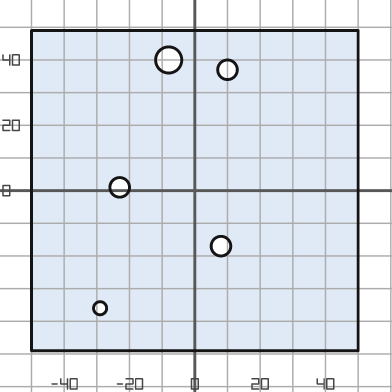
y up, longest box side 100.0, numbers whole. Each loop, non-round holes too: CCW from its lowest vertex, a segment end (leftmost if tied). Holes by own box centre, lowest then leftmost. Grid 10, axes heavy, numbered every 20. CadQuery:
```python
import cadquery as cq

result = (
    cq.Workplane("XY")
    .moveTo(-50.0, -49.0)
    .lineTo(50.0, -49.0)
    .lineTo(50.0, 49.0)
    .lineTo(-50.0, 49.0)
    .close()
    .moveTo(-29.0, -36.0)
    .circle(2.0)
    .moveTo(8.0, -17.0)
    .circle(3.0)
    .moveTo(-23.0, 1.0)
    .circle(3.0)
    .moveTo(10.0, 37.0)
    .circle(3.0)
    .moveTo(-8.0, 40.0)
    .circle(4.0)
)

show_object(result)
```